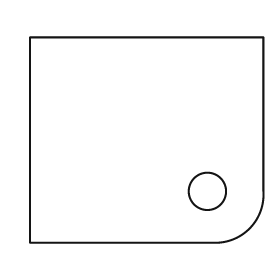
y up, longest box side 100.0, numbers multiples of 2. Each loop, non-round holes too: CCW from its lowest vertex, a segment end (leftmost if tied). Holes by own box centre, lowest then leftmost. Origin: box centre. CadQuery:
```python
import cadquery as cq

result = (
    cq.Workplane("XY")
    .moveTo(-50.0, -44.0)
    .lineTo(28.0, -44.0)
    .threePointArc((44.0, -38.0), (50.0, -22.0))
    .lineTo(50.0, 44.0)
    .lineTo(-50.0, 44.0)
    .close()
    .moveTo(26.0, -22.0)
    .circle(8.0)
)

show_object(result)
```